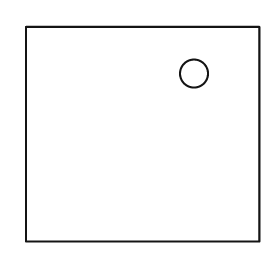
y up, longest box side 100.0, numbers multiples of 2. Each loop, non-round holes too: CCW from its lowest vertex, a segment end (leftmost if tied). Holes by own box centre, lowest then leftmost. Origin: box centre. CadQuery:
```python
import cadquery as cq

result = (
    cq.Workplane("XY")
    .moveTo(-50.0, -46.0)
    .lineTo(50.0, -46.0)
    .lineTo(50.0, 46.0)
    .lineTo(-50.0, 46.0)
    .close()
    .moveTo(22.0, 26.0)
    .circle(6.0)
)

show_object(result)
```